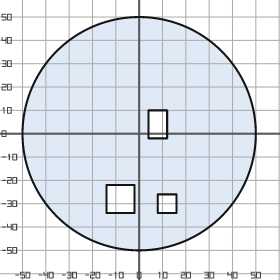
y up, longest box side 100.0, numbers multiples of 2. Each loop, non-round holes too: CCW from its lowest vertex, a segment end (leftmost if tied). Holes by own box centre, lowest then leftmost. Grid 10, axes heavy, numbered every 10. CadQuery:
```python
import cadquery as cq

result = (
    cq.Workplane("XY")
    .moveTo(0.0, 0.0)
    .circle(50.0)
    .moveTo(8.0, -34.0)
    .lineTo(16.0, -34.0)
    .lineTo(16.0, -26.0)
    .lineTo(8.0, -26.0)
    .close()
    .moveTo(-14.0, -34.0)
    .lineTo(-2.0, -34.0)
    .lineTo(-2.0, -22.0)
    .lineTo(-14.0, -22.0)
    .close()
    .moveTo(4.0, -2.0)
    .lineTo(12.0, -2.0)
    .lineTo(12.0, 10.0)
    .lineTo(4.0, 10.0)
    .close()
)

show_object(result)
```